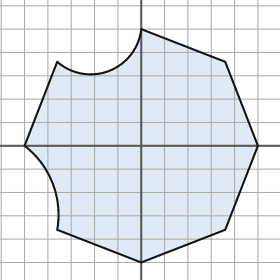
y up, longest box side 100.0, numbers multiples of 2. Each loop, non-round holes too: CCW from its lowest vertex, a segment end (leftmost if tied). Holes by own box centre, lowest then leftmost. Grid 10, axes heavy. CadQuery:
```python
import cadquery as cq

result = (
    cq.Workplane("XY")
    .moveTo(0.0, -50.0)
    .lineTo(36.0, -36.0)
    .lineTo(50.0, 0.0)
    .lineTo(36.0, 36.0)
    .lineTo(0.0, 50.0)
    .threePointArc((-14.0, 32.0), (-36.0, 36.0))
    .lineTo(-50.0, 0.0)
    .threePointArc((-38.0, -16.0), (-36.0, -36.0))
    .close()
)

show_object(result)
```